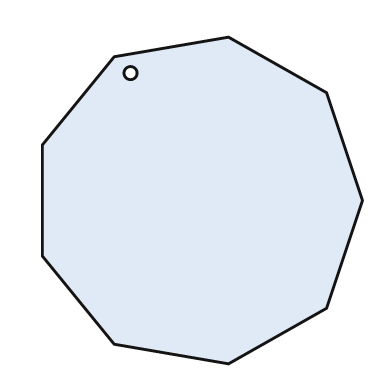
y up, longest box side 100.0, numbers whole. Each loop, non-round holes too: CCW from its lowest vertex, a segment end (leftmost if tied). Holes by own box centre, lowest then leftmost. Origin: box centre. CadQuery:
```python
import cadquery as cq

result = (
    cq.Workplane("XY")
    .moveTo(8.0, -50.0)
    .lineTo(38.0, -33.0)
    .lineTo(49.0, 0.0)
    .lineTo(38.0, 33.0)
    .lineTo(8.0, 50.0)
    .lineTo(-27.0, 44.0)
    .lineTo(-49.0, 17.0)
    .lineTo(-49.0, -17.0)
    .lineTo(-27.0, -44.0)
    .close()
    .moveTo(-22.0, 39.0)
    .circle(2.0)
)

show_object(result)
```